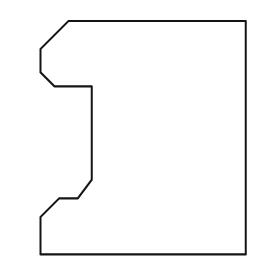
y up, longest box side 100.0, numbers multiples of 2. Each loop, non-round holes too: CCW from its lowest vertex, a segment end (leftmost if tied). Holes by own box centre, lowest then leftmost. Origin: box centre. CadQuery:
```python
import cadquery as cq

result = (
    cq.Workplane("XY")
    .moveTo(-44.0, -50.0)
    .lineTo(44.0, -50.0)
    .lineTo(44.0, 50.0)
    .lineTo(-32.0, 50.0)
    .lineTo(-44.0, 38.0)
    .lineTo(-44.0, 28.0)
    .lineTo(-38.0, 22.0)
    .lineTo(-22.0, 22.0)
    .lineTo(-22.0, -18.0)
    .lineTo(-28.0, -26.0)
    .lineTo(-36.0, -26.0)
    .lineTo(-44.0, -34.0)
    .close()
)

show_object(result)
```